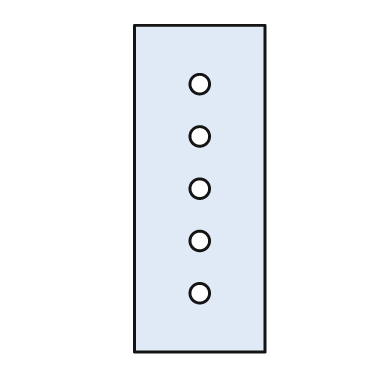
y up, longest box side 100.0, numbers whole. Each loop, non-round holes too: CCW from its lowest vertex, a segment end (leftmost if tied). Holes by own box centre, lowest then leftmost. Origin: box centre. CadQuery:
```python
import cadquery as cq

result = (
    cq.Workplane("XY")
    .moveTo(-20.0, -50.0)
    .lineTo(20.0, -50.0)
    .lineTo(20.0, 50.0)
    .lineTo(-20.0, 50.0)
    .close()
    .moveTo(0.0, -32.0)
    .circle(3.0)
    .moveTo(0.0, -16.0)
    .circle(3.0)
    .moveTo(0.0, 0.0)
    .circle(3.0)
    .moveTo(0.0, 16.0)
    .circle(3.0)
    .moveTo(0.0, 32.0)
    .circle(3.0)
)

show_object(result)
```